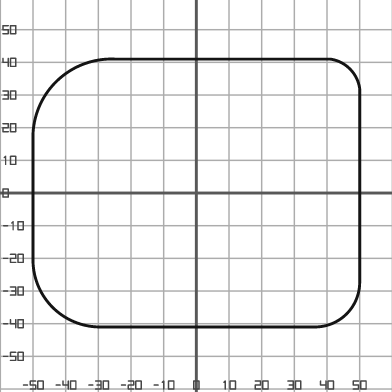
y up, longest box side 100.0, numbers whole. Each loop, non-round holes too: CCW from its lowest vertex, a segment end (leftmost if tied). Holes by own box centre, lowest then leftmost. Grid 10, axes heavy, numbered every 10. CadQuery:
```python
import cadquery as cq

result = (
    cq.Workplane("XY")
    .moveTo(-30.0, -41.0)
    .lineTo(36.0, -41.0)
    .threePointArc((46.0, -37.0), (50.0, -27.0))
    .lineTo(50.0, 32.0)
    .threePointArc((47.0, 38.0), (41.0, 41.0))
    .lineTo(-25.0, 41.0)
    .threePointArc((-43.0, 34.0), (-50.0, 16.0))
    .lineTo(-50.0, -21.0)
    .threePointArc((-44.0, -35.0), (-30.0, -41.0))
    .close()
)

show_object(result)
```